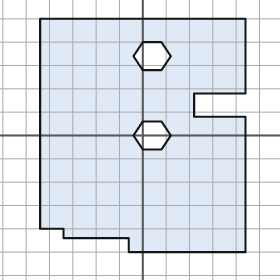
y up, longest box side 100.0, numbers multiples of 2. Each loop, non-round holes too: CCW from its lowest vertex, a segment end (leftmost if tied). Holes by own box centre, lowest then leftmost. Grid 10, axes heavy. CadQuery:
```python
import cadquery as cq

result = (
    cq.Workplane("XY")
    .moveTo(-6.0, -50.0)
    .lineTo(44.0, -50.0)
    .lineTo(44.0, 8.0)
    .lineTo(22.0, 8.0)
    .lineTo(22.0, 18.0)
    .lineTo(44.0, 18.0)
    .lineTo(44.0, 50.0)
    .lineTo(-44.0, 50.0)
    .lineTo(-44.0, -40.0)
    .lineTo(-34.0, -40.0)
    .lineTo(-34.0, -44.0)
    .lineTo(-6.0, -44.0)
    .close()
    .moveTo(0.0, -6.0)
    .lineTo(8.0, -6.0)
    .lineTo(12.0, 0.0)
    .lineTo(8.0, 6.0)
    .lineTo(0.0, 6.0)
    .lineTo(-4.0, 0.0)
    .close()
    .moveTo(0.0, 28.0)
    .lineTo(8.0, 28.0)
    .lineTo(12.0, 34.0)
    .lineTo(8.0, 40.0)
    .lineTo(0.0, 40.0)
    .lineTo(-4.0, 34.0)
    .close()
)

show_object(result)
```